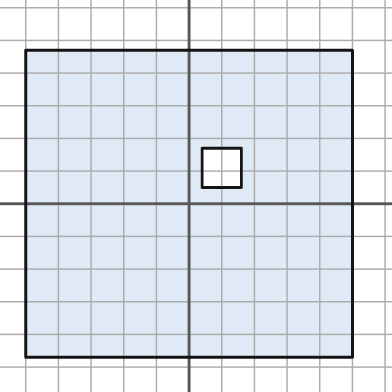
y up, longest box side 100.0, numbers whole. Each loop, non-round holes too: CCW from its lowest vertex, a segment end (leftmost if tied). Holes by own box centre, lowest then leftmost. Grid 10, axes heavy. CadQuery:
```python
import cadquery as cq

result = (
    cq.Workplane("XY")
    .moveTo(-50.0, -47.0)
    .lineTo(50.0, -47.0)
    .lineTo(50.0, 47.0)
    .lineTo(-50.0, 47.0)
    .close()
    .moveTo(4.0, 5.0)
    .lineTo(16.0, 5.0)
    .lineTo(16.0, 17.0)
    .lineTo(4.0, 17.0)
    .close()
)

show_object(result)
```